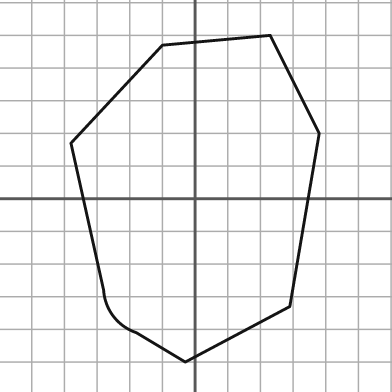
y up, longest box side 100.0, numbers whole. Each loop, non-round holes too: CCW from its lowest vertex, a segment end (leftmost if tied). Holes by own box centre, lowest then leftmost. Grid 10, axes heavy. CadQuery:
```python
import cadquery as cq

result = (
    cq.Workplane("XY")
    .moveTo(-3.0, -50.0)
    .lineTo(29.0, -33.0)
    .lineTo(38.0, 20.0)
    .lineTo(23.0, 50.0)
    .lineTo(-10.0, 47.0)
    .lineTo(-38.0, 17.0)
    .lineTo(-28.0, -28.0)
    .threePointArc((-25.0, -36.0), (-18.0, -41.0))
    .close()
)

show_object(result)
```